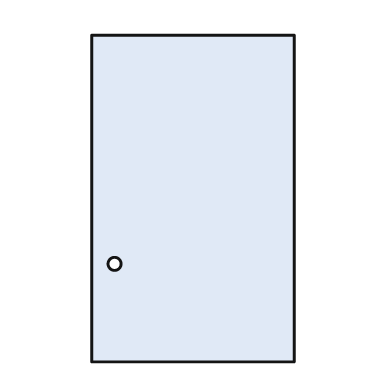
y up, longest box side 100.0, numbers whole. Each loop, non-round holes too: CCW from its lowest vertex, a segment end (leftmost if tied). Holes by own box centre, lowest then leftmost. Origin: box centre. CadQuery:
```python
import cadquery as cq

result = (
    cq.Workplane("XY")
    .moveTo(-31.0, -50.0)
    .lineTo(31.0, -50.0)
    .lineTo(31.0, 50.0)
    .lineTo(-31.0, 50.0)
    .close()
    .moveTo(-24.0, -20.0)
    .circle(2.0)
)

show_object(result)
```